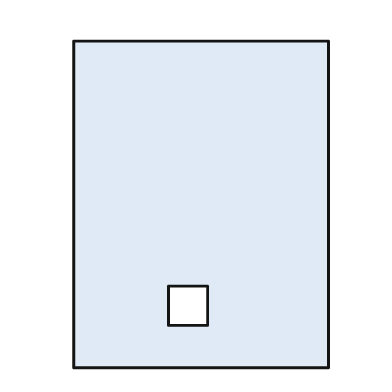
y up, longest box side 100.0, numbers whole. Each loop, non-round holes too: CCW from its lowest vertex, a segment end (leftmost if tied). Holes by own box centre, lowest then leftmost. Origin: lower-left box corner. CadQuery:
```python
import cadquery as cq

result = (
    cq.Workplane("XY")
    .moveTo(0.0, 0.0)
    .lineTo(78.0, 0.0)
    .lineTo(78.0, 100.0)
    .lineTo(0.0, 100.0)
    .close()
    .moveTo(29.0, 13.0)
    .lineTo(41.0, 13.0)
    .lineTo(41.0, 25.0)
    .lineTo(29.0, 25.0)
    .close()
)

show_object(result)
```